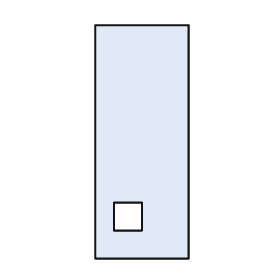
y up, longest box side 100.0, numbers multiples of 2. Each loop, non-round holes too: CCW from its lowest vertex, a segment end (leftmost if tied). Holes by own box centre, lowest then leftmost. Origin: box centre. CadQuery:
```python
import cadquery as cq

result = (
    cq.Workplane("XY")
    .moveTo(-20.0, -50.0)
    .lineTo(20.0, -50.0)
    .lineTo(20.0, 50.0)
    .lineTo(-20.0, 50.0)
    .close()
    .moveTo(-12.0, -38.0)
    .lineTo(0.0, -38.0)
    .lineTo(0.0, -26.0)
    .lineTo(-12.0, -26.0)
    .close()
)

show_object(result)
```